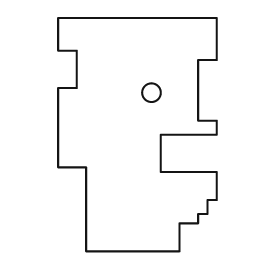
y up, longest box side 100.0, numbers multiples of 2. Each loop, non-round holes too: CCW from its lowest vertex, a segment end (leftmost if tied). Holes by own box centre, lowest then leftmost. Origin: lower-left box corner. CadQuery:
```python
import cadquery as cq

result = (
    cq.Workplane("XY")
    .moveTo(12.0, 0.0)
    .lineTo(52.0, 0.0)
    .lineTo(52.0, 12.0)
    .lineTo(60.0, 12.0)
    .lineTo(60.0, 16.0)
    .lineTo(64.0, 16.0)
    .lineTo(64.0, 22.0)
    .lineTo(68.0, 22.0)
    .lineTo(68.0, 34.0)
    .lineTo(44.0, 34.0)
    .lineTo(44.0, 50.0)
    .lineTo(68.0, 50.0)
    .lineTo(68.0, 56.0)
    .lineTo(60.0, 56.0)
    .lineTo(60.0, 82.0)
    .lineTo(68.0, 82.0)
    .lineTo(68.0, 100.0)
    .lineTo(0.0, 100.0)
    .lineTo(0.0, 86.0)
    .lineTo(8.0, 86.0)
    .lineTo(8.0, 70.0)
    .lineTo(0.0, 70.0)
    .lineTo(0.0, 36.0)
    .lineTo(12.0, 36.0)
    .close()
    .moveTo(40.0, 68.0)
    .circle(4.0)
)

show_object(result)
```